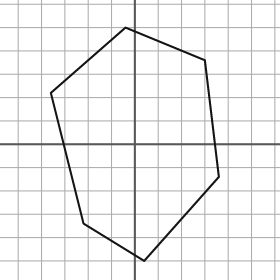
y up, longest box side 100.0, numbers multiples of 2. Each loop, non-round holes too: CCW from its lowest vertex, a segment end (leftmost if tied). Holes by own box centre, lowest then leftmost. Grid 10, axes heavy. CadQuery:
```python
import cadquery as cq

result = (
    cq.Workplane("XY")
    .moveTo(4.0, -50.0)
    .lineTo(36.0, -14.0)
    .lineTo(30.0, 36.0)
    .lineTo(-4.0, 50.0)
    .lineTo(-36.0, 22.0)
    .lineTo(-22.0, -34.0)
    .close()
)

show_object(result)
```